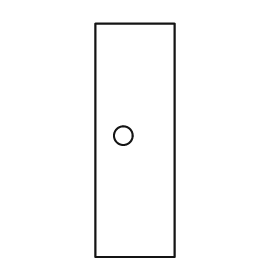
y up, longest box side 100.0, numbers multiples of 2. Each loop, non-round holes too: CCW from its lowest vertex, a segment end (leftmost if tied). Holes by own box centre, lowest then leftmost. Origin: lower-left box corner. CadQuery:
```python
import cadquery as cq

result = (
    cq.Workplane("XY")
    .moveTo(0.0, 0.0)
    .lineTo(34.0, 0.0)
    .lineTo(34.0, 100.0)
    .lineTo(0.0, 100.0)
    .close()
    .moveTo(12.0, 52.0)
    .circle(4.0)
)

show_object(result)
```